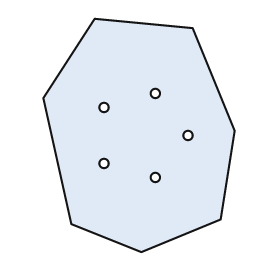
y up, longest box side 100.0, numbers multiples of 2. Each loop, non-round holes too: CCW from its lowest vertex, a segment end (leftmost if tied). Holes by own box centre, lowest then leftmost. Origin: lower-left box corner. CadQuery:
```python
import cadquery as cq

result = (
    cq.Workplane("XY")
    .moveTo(42.0, 0.0)
    .lineTo(76.0, 14.0)
    .lineTo(82.0, 52.0)
    .lineTo(64.0, 96.0)
    .lineTo(22.0, 100.0)
    .lineTo(0.0, 66.0)
    .lineTo(12.0, 12.0)
    .close()
    .moveTo(48.0, 32.0)
    .circle(2.0)
    .moveTo(26.0, 38.0)
    .circle(2.0)
    .moveTo(62.0, 50.0)
    .circle(2.0)
    .moveTo(26.0, 62.0)
    .circle(2.0)
    .moveTo(48.0, 68.0)
    .circle(2.0)
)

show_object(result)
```